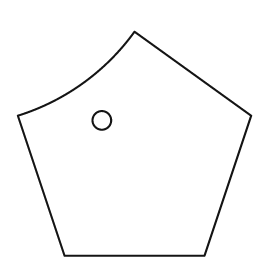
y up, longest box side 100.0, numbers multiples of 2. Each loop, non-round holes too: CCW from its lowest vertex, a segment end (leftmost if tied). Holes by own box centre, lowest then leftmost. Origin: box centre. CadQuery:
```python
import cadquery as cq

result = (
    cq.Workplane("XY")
    .moveTo(-30.0, -48.0)
    .lineTo(30.0, -48.0)
    .lineTo(50.0, 12.0)
    .lineTo(0.0, 48.0)
    .threePointArc((-22.0, 26.0), (-50.0, 12.0))
    .close()
    .moveTo(-14.0, 10.0)
    .circle(4.0)
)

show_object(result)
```